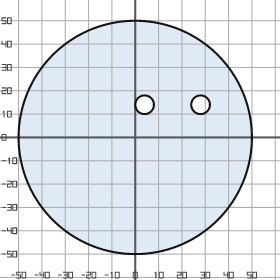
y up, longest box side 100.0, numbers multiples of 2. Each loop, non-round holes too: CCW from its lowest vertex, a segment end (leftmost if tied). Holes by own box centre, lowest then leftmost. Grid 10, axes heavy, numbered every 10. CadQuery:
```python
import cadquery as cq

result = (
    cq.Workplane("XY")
    .moveTo(0.0, 0.0)
    .circle(50.0)
    .moveTo(4.0, 14.0)
    .circle(4.0)
    .moveTo(28.0, 14.0)
    .circle(4.0)
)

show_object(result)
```